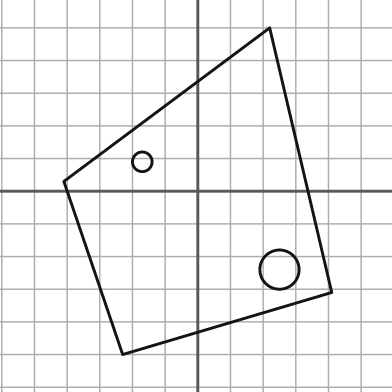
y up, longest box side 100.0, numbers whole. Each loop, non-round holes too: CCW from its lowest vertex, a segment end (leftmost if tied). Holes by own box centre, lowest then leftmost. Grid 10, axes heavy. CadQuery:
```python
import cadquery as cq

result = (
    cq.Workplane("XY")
    .moveTo(-23.0, -50.0)
    .lineTo(41.0, -31.0)
    .lineTo(22.0, 50.0)
    .lineTo(-41.0, 3.0)
    .close()
    .moveTo(25.0, -24.0)
    .circle(6.0)
    .moveTo(-17.0, 9.0)
    .circle(3.0)
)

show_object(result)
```